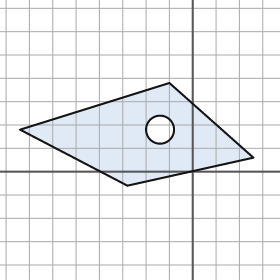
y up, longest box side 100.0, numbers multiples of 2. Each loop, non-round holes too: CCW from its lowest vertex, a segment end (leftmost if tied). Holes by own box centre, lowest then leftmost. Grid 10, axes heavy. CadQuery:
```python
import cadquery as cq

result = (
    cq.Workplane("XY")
    .moveTo(-28.0, -6.0)
    .lineTo(26.0, 6.0)
    .lineTo(-10.0, 38.0)
    .lineTo(-74.0, 18.0)
    .close()
    .moveTo(-14.0, 18.0)
    .circle(6.0)
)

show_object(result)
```